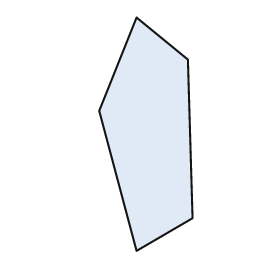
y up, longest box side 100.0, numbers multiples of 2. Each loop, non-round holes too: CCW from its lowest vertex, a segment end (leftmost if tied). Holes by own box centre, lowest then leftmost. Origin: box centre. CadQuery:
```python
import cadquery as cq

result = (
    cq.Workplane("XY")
    .moveTo(-4.0, -50.0)
    .lineTo(20.0, -36.0)
    .lineTo(18.0, 32.0)
    .lineTo(-4.0, 50.0)
    .lineTo(-20.0, 10.0)
    .close()
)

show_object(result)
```